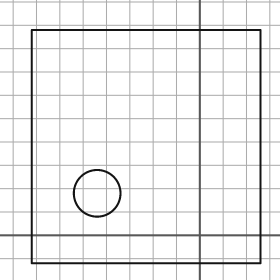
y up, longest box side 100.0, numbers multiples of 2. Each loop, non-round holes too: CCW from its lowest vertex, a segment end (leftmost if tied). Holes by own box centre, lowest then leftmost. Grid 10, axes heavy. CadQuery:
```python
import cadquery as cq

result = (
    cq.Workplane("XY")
    .moveTo(-72.0, -12.0)
    .lineTo(26.0, -12.0)
    .lineTo(26.0, 88.0)
    .lineTo(-72.0, 88.0)
    .close()
    .moveTo(-44.0, 18.0)
    .circle(10.0)
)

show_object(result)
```